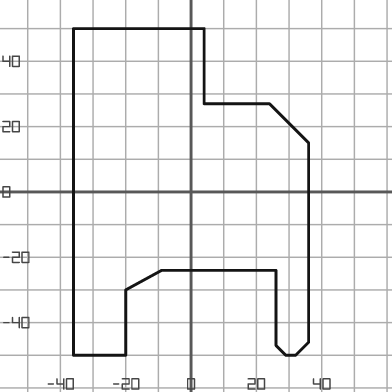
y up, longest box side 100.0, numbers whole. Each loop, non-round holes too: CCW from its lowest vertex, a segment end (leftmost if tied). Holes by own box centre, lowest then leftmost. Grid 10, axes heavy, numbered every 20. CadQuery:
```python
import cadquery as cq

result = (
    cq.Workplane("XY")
    .moveTo(-36.0, -50.0)
    .lineTo(-20.0, -50.0)
    .lineTo(-20.0, -30.0)
    .lineTo(-9.0, -24.0)
    .lineTo(26.0, -24.0)
    .lineTo(26.0, -47.0)
    .lineTo(29.0, -50.0)
    .lineTo(32.0, -50.0)
    .lineTo(36.0, -46.0)
    .lineTo(36.0, 15.0)
    .lineTo(24.0, 27.0)
    .lineTo(4.0, 27.0)
    .lineTo(4.0, 50.0)
    .lineTo(-36.0, 50.0)
    .close()
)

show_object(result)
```